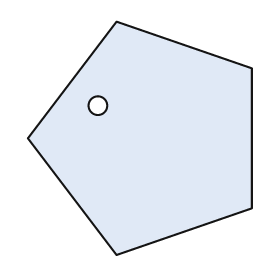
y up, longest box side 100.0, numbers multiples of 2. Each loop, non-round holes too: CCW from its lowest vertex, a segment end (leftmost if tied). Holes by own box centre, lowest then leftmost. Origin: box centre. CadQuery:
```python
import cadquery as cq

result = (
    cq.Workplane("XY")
    .moveTo(-10.0, -50.0)
    .lineTo(48.0, -30.0)
    .lineTo(48.0, 30.0)
    .lineTo(-10.0, 50.0)
    .lineTo(-48.0, 0.0)
    .close()
    .moveTo(-18.0, 14.0)
    .circle(4.0)
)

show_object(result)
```